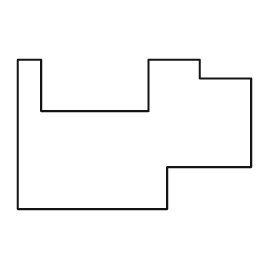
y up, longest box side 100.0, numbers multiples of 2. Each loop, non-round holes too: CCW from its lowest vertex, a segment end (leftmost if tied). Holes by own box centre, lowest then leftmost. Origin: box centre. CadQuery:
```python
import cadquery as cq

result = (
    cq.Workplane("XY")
    .moveTo(-50.0, -32.0)
    .lineTo(14.0, -32.0)
    .lineTo(14.0, -14.0)
    .lineTo(50.0, -14.0)
    .lineTo(50.0, 24.0)
    .lineTo(28.0, 24.0)
    .lineTo(28.0, 32.0)
    .lineTo(6.0, 32.0)
    .lineTo(6.0, 10.0)
    .lineTo(-40.0, 10.0)
    .lineTo(-40.0, 32.0)
    .lineTo(-50.0, 32.0)
    .close()
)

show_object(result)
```